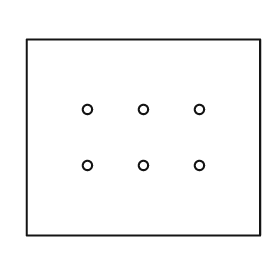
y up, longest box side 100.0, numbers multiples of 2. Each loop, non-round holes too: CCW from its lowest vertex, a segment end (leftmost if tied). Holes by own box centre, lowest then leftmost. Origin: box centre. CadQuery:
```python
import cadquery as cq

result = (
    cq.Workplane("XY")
    .moveTo(-50.0, -42.0)
    .lineTo(50.0, -42.0)
    .lineTo(50.0, 42.0)
    .lineTo(-50.0, 42.0)
    .close()
    .moveTo(-24.0, -12.0)
    .circle(2.0)
    .moveTo(0.0, -12.0)
    .circle(2.0)
    .moveTo(24.0, -12.0)
    .circle(2.0)
    .moveTo(-24.0, 12.0)
    .circle(2.0)
    .moveTo(0.0, 12.0)
    .circle(2.0)
    .moveTo(24.0, 12.0)
    .circle(2.0)
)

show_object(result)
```